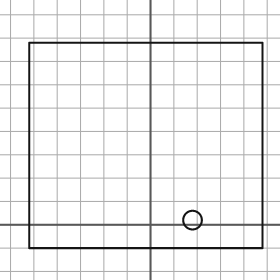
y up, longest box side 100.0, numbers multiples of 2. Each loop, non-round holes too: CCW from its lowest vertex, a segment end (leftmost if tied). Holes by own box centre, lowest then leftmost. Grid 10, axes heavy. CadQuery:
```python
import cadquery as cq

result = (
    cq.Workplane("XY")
    .moveTo(-52.0, -10.0)
    .lineTo(48.0, -10.0)
    .lineTo(48.0, 78.0)
    .lineTo(-52.0, 78.0)
    .close()
    .moveTo(18.0, 2.0)
    .circle(4.0)
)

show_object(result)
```